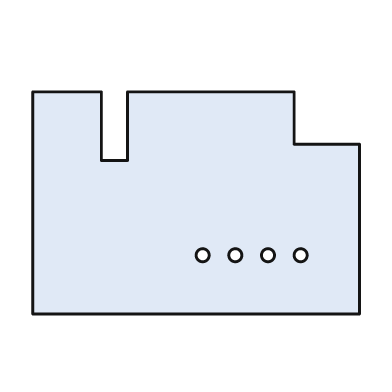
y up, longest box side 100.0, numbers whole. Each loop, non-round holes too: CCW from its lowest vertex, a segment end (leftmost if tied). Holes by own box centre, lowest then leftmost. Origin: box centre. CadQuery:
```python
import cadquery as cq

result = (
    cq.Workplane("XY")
    .moveTo(-50.0, -34.0)
    .lineTo(50.0, -34.0)
    .lineTo(50.0, 18.0)
    .lineTo(30.0, 18.0)
    .lineTo(30.0, 34.0)
    .lineTo(-21.0, 34.0)
    .lineTo(-21.0, 13.0)
    .lineTo(-29.0, 13.0)
    .lineTo(-29.0, 34.0)
    .lineTo(-50.0, 34.0)
    .close()
    .moveTo(2.0, -16.0)
    .circle(2.0)
    .moveTo(12.0, -16.0)
    .circle(2.0)
    .moveTo(22.0, -16.0)
    .circle(2.0)
    .moveTo(32.0, -16.0)
    .circle(2.0)
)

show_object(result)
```